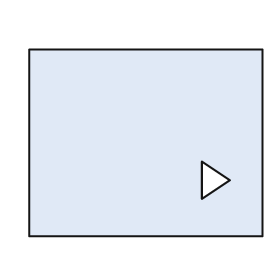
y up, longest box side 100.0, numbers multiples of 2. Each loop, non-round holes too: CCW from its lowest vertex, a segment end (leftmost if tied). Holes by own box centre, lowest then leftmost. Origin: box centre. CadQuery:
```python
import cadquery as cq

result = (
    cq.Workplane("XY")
    .moveTo(-50.0, -40.0)
    .lineTo(50.0, -40.0)
    .lineTo(50.0, 40.0)
    .lineTo(-50.0, 40.0)
    .close()
    .moveTo(24.0, -24.0)
    .lineTo(36.0, -16.0)
    .lineTo(24.0, -8.0)
    .close()
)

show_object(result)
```